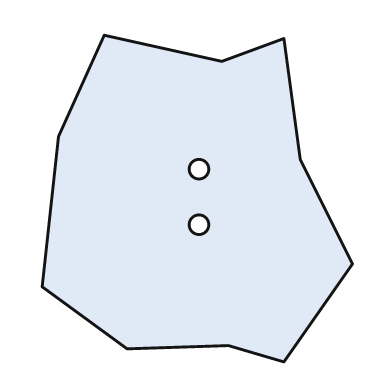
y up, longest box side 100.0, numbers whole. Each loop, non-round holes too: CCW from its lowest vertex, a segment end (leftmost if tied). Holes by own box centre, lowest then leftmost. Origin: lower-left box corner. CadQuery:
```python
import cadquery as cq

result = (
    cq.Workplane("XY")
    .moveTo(74.0, 0.0)
    .lineTo(95.0, 30.0)
    .lineTo(79.0, 62.0)
    .lineTo(74.0, 99.0)
    .lineTo(55.0, 92.0)
    .lineTo(19.0, 100.0)
    .lineTo(5.0, 69.0)
    .lineTo(0.0, 23.0)
    .lineTo(26.0, 4.0)
    .lineTo(57.0, 5.0)
    .close()
    .moveTo(48.0, 42.0)
    .circle(3.0)
    .moveTo(48.0, 59.0)
    .circle(3.0)
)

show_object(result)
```